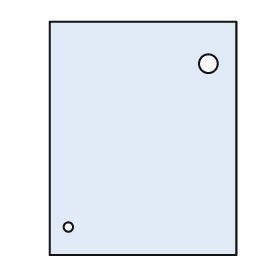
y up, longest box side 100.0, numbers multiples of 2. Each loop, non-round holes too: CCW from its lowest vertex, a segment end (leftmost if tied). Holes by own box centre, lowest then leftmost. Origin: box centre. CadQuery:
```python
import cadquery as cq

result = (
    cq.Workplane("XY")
    .moveTo(-40.0, -50.0)
    .lineTo(40.0, -50.0)
    .lineTo(40.0, 50.0)
    .lineTo(-40.0, 50.0)
    .close()
    .moveTo(-32.0, -38.0)
    .circle(2.0)
    .moveTo(28.0, 32.0)
    .circle(4.0)
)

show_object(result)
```